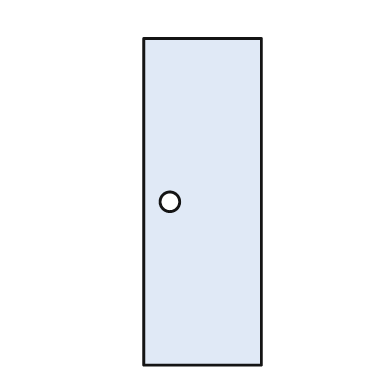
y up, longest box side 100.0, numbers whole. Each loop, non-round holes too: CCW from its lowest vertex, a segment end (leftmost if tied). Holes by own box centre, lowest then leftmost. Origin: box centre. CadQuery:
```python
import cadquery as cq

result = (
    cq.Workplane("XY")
    .moveTo(-18.0, -50.0)
    .lineTo(18.0, -50.0)
    .lineTo(18.0, 50.0)
    .lineTo(-18.0, 50.0)
    .close()
    .moveTo(-10.0, 0.0)
    .circle(3.0)
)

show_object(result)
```